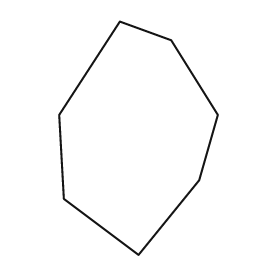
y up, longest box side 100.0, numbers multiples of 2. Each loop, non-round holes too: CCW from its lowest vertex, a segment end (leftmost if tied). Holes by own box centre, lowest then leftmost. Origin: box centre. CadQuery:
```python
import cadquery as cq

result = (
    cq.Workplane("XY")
    .moveTo(0.0, -50.0)
    .lineTo(26.0, -18.0)
    .lineTo(34.0, 10.0)
    .lineTo(14.0, 42.0)
    .lineTo(-8.0, 50.0)
    .lineTo(-34.0, 10.0)
    .lineTo(-32.0, -26.0)
    .close()
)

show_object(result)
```